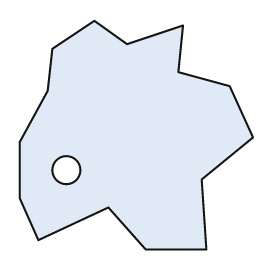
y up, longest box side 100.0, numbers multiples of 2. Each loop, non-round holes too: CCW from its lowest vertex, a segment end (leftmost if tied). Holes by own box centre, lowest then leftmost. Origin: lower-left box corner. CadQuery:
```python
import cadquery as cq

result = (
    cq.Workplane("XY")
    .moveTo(54.0, 0.0)
    .lineTo(80.0, 0.0)
    .lineTo(78.0, 30.0)
    .lineTo(100.0, 48.0)
    .lineTo(90.0, 70.0)
    .lineTo(68.0, 76.0)
    .lineTo(70.0, 96.0)
    .lineTo(46.0, 88.0)
    .lineTo(32.0, 98.0)
    .lineTo(14.0, 86.0)
    .lineTo(12.0, 68.0)
    .lineTo(0.0, 46.0)
    .lineTo(0.0, 22.0)
    .lineTo(8.0, 4.0)
    .lineTo(38.0, 18.0)
    .close()
    .moveTo(20.0, 34.0)
    .circle(6.0)
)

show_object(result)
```